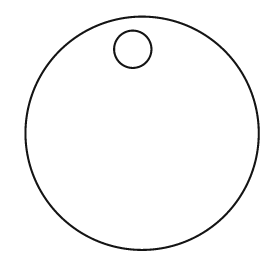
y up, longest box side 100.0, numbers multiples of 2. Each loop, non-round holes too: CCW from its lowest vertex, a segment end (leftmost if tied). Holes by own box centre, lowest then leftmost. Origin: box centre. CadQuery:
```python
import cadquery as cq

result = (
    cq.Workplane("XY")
    .moveTo(0.0, 0.0)
    .circle(50.0)
    .moveTo(-4.0, 36.0)
    .circle(8.0)
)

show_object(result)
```